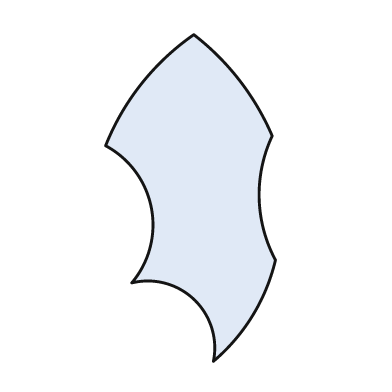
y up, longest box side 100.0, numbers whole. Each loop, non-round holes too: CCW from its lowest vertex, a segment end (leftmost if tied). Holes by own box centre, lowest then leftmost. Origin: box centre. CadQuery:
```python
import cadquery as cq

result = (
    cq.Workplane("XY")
    .moveTo(7.0, -50.0)
    .threePointArc((19.0, -36.0), (26.0, -19.0))
    .threePointArc((21.0, 0.0), (25.0, 19.0))
    .threePointArc((15.0, 36.0), (1.0, 50.0))
    .threePointArc((-15.0, 35.0), (-26.0, 16.0))
    .threePointArc((-12.0, -3.0), (-18.0, -26.0))
    .threePointArc((1.0, -31.0), (7.0, -50.0))
    .close()
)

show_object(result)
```